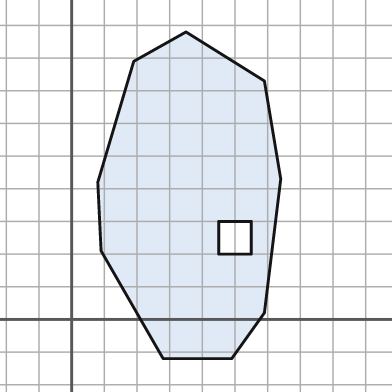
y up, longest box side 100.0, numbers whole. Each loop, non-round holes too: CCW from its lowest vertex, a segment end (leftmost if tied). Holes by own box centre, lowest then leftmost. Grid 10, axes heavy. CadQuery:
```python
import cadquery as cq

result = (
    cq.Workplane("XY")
    .moveTo(28.0, -12.0)
    .lineTo(49.0, -12.0)
    .lineTo(59.0, 2.0)
    .lineTo(64.0, 43.0)
    .lineTo(59.0, 73.0)
    .lineTo(35.0, 88.0)
    .lineTo(19.0, 79.0)
    .lineTo(8.0, 42.0)
    .lineTo(9.0, 21.0)
    .close()
    .moveTo(45.0, 20.0)
    .lineTo(55.0, 20.0)
    .lineTo(55.0, 30.0)
    .lineTo(45.0, 30.0)
    .close()
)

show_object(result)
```